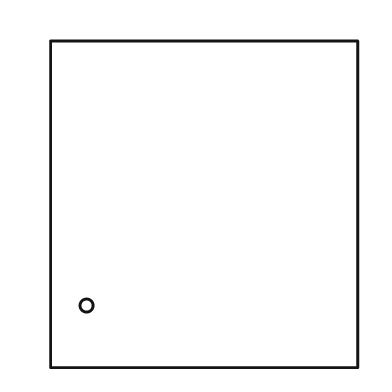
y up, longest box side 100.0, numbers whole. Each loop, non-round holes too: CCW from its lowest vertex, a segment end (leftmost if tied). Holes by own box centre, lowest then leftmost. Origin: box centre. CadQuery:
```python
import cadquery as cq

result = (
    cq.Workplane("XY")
    .moveTo(-47.0, -50.0)
    .lineTo(47.0, -50.0)
    .lineTo(47.0, 50.0)
    .lineTo(-47.0, 50.0)
    .close()
    .moveTo(-36.0, -31.0)
    .circle(2.0)
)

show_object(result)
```